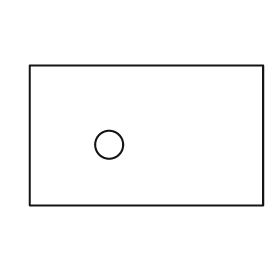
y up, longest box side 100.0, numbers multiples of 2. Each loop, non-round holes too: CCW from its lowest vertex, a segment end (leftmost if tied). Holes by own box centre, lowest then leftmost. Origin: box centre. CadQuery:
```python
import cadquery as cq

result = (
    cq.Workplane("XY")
    .moveTo(-50.0, -30.0)
    .lineTo(50.0, -30.0)
    .lineTo(50.0, 30.0)
    .lineTo(-50.0, 30.0)
    .close()
    .moveTo(-16.0, -4.0)
    .circle(6.0)
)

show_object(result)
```